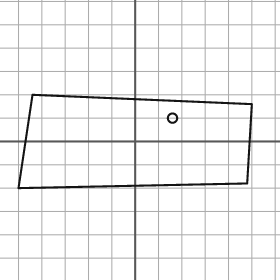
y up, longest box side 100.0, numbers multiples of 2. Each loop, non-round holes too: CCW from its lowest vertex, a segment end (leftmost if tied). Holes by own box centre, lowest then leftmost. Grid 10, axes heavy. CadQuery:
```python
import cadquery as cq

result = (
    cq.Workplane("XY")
    .moveTo(-50.0, -20.0)
    .lineTo(48.0, -18.0)
    .lineTo(50.0, 16.0)
    .lineTo(-44.0, 20.0)
    .close()
    .moveTo(16.0, 10.0)
    .circle(2.0)
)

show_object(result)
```